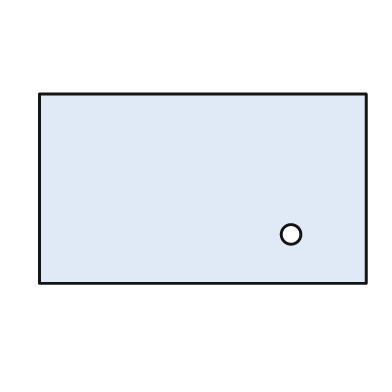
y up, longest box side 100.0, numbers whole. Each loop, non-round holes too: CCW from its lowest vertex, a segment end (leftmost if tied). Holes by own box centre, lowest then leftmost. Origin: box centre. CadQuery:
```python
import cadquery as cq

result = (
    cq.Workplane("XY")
    .moveTo(-50.0, -29.0)
    .lineTo(50.0, -29.0)
    .lineTo(50.0, 29.0)
    .lineTo(-50.0, 29.0)
    .close()
    .moveTo(27.0, -14.0)
    .circle(3.0)
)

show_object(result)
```